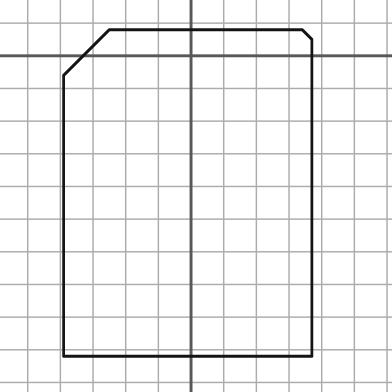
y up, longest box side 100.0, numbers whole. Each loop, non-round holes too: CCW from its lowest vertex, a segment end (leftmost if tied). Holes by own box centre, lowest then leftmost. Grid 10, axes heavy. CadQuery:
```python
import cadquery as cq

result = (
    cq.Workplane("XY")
    .moveTo(-39.0, -92.0)
    .lineTo(37.0, -92.0)
    .lineTo(37.0, 5.0)
    .lineTo(34.0, 8.0)
    .lineTo(-25.0, 8.0)
    .lineTo(-39.0, -6.0)
    .close()
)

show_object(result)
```